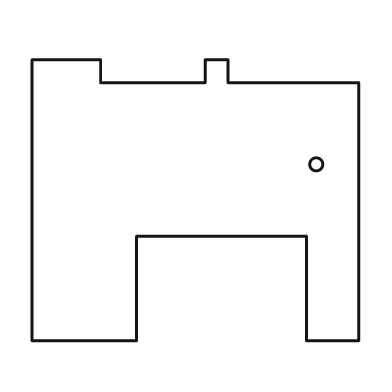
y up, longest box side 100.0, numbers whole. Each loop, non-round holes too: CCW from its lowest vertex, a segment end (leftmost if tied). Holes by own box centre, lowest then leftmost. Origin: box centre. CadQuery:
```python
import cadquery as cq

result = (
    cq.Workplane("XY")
    .moveTo(-50.0, -43.0)
    .lineTo(-18.0, -43.0)
    .lineTo(-18.0, -11.0)
    .lineTo(34.0, -11.0)
    .lineTo(34.0, -43.0)
    .lineTo(50.0, -43.0)
    .lineTo(50.0, 36.0)
    .lineTo(10.0, 36.0)
    .lineTo(10.0, 43.0)
    .lineTo(3.0, 43.0)
    .lineTo(3.0, 36.0)
    .lineTo(-29.0, 36.0)
    .lineTo(-29.0, 43.0)
    .lineTo(-50.0, 43.0)
    .close()
    .moveTo(37.0, 11.0)
    .circle(2.0)
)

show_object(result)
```